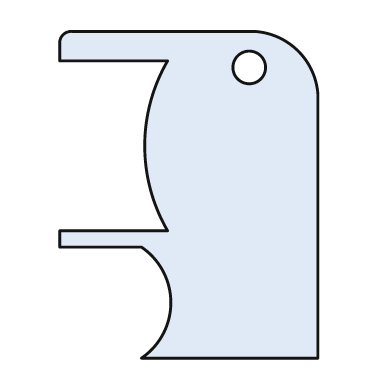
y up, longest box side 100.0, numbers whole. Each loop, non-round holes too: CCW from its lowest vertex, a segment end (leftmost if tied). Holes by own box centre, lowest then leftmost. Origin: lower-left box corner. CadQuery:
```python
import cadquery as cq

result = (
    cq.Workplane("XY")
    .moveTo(25.0, 0.0)
    .lineTo(79.0, 0.0)
    .lineTo(79.0, 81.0)
    .threePointArc((73.0, 94.0), (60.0, 100.0))
    .lineTo(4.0, 100.0)
    .threePointArc((1.0, 99.0), (0.0, 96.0))
    .lineTo(0.0, 91.0)
    .lineTo(33.0, 91.0)
    .threePointArc((26.0, 65.0), (33.0, 39.0))
    .lineTo(0.0, 39.0)
    .lineTo(0.0, 34.0)
    .lineTo(25.0, 34.0)
    .threePointArc((34.0, 17.0), (25.0, 0.0))
    .close()
    .moveTo(58.0, 89.0)
    .circle(5.0)
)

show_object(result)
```